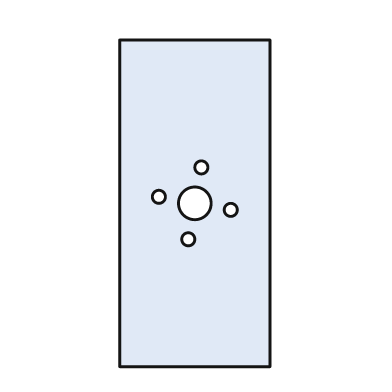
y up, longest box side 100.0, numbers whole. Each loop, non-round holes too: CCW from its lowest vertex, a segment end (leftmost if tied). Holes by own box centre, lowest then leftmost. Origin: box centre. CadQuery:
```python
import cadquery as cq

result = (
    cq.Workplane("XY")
    .moveTo(-23.0, -50.0)
    .lineTo(23.0, -50.0)
    .lineTo(23.0, 50.0)
    .lineTo(-23.0, 50.0)
    .close()
    .moveTo(-2.0, -11.0)
    .circle(2.0)
    .moveTo(11.0, -2.0)
    .circle(2.0)
    .moveTo(0.0, 0.0)
    .circle(5.0)
    .moveTo(-11.0, 2.0)
    .circle(2.0)
    .moveTo(2.0, 11.0)
    .circle(2.0)
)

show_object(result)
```